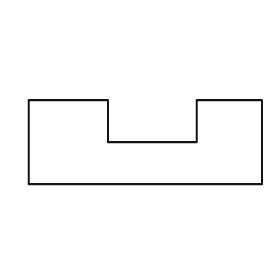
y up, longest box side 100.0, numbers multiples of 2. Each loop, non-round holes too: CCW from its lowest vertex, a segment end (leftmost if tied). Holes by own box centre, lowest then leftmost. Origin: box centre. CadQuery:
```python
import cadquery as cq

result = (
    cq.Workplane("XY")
    .moveTo(-50.0, -18.0)
    .lineTo(50.0, -18.0)
    .lineTo(50.0, 18.0)
    .lineTo(22.0, 18.0)
    .lineTo(22.0, 0.0)
    .lineTo(-16.0, 0.0)
    .lineTo(-16.0, 18.0)
    .lineTo(-50.0, 18.0)
    .close()
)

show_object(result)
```